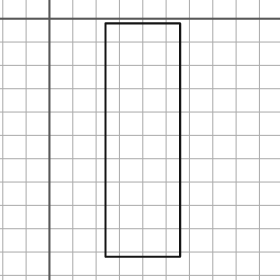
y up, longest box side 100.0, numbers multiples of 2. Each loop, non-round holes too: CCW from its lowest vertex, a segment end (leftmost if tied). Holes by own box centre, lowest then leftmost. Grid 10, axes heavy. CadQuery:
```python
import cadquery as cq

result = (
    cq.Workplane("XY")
    .moveTo(24.0, -102.0)
    .lineTo(56.0, -102.0)
    .lineTo(56.0, -2.0)
    .lineTo(24.0, -2.0)
    .close()
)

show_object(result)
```